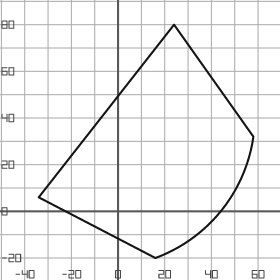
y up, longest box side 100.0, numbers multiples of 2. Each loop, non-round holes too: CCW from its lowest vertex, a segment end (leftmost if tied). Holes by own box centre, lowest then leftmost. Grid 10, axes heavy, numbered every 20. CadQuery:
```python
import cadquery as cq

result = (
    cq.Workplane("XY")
    .moveTo(16.0, -20.0)
    .threePointArc((44.0, 0.0), (58.0, 32.0))
    .lineTo(24.0, 80.0)
    .lineTo(-34.0, 6.0)
    .close()
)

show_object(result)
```